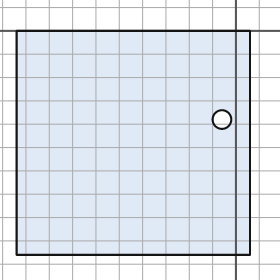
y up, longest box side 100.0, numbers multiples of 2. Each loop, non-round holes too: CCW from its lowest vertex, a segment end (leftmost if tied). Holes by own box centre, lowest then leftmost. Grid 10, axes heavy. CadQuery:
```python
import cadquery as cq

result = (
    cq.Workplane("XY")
    .moveTo(-94.0, -96.0)
    .lineTo(6.0, -96.0)
    .lineTo(6.0, 0.0)
    .lineTo(-94.0, 0.0)
    .close()
    .moveTo(-6.0, -38.0)
    .circle(4.0)
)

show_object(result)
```